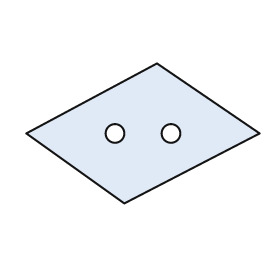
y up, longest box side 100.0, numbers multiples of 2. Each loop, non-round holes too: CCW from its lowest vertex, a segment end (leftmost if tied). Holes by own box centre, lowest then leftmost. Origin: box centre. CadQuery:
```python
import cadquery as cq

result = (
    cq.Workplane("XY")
    .moveTo(-8.0, -30.0)
    .lineTo(50.0, 0.0)
    .lineTo(6.0, 30.0)
    .lineTo(-50.0, 0.0)
    .close()
    .moveTo(-12.0, 0.0)
    .circle(4.0)
    .moveTo(12.0, 0.0)
    .circle(4.0)
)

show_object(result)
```